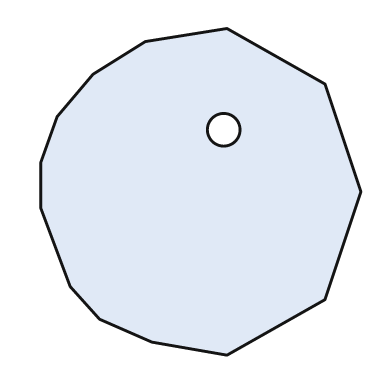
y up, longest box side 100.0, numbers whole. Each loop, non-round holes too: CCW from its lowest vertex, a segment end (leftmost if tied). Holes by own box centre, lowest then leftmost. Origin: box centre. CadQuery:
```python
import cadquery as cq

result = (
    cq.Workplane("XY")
    .moveTo(8.0, -50.0)
    .lineTo(38.0, -33.0)
    .lineTo(49.0, 0.0)
    .lineTo(38.0, 33.0)
    .lineTo(8.0, 50.0)
    .lineTo(-17.0, 46.0)
    .lineTo(-33.0, 36.0)
    .lineTo(-44.0, 23.0)
    .lineTo(-49.0, 9.0)
    .lineTo(-49.0, -5.0)
    .lineTo(-40.0, -29.0)
    .lineTo(-31.0, -39.0)
    .lineTo(-15.0, -46.0)
    .close()
    .moveTo(7.0, 19.0)
    .circle(5.0)
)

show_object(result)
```